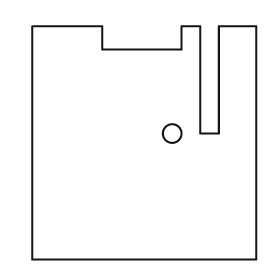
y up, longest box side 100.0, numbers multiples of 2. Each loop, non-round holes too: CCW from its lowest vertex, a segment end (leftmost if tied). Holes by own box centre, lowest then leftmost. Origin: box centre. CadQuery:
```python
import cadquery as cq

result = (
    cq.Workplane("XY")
    .moveTo(-48.0, -50.0)
    .lineTo(48.0, -50.0)
    .lineTo(48.0, 50.0)
    .lineTo(32.0, 50.0)
    .lineTo(32.0, 4.0)
    .lineTo(24.0, 4.0)
    .lineTo(24.0, 50.0)
    .lineTo(16.0, 50.0)
    .lineTo(16.0, 40.0)
    .lineTo(-18.0, 40.0)
    .lineTo(-18.0, 50.0)
    .lineTo(-48.0, 50.0)
    .close()
    .moveTo(12.0, 4.0)
    .circle(4.0)
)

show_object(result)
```